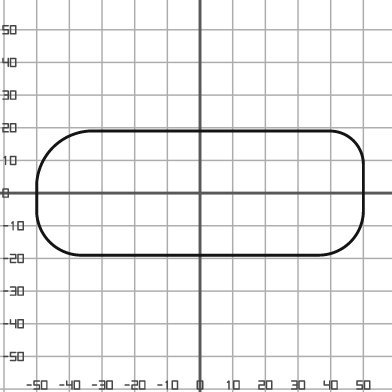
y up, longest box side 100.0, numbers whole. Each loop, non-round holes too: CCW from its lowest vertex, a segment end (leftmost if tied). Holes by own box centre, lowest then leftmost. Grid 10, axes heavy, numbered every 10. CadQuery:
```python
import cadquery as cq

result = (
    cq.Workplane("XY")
    .moveTo(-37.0, -19.0)
    .lineTo(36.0, -19.0)
    .threePointArc((46.0, -15.0), (50.0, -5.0))
    .lineTo(50.0, 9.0)
    .threePointArc((47.0, 16.0), (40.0, 19.0))
    .lineTo(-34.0, 19.0)
    .threePointArc((-45.0, 14.0), (-50.0, 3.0))
    .lineTo(-50.0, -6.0)
    .threePointArc((-46.0, -15.0), (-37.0, -19.0))
    .close()
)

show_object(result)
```